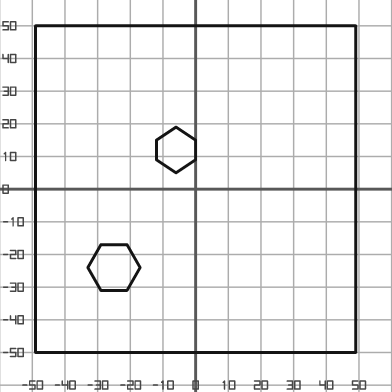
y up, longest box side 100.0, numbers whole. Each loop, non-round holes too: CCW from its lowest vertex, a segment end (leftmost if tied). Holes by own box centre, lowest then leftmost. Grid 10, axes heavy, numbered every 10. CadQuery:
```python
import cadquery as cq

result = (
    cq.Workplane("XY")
    .moveTo(-49.0, -50.0)
    .lineTo(49.0, -50.0)
    .lineTo(49.0, 50.0)
    .lineTo(-49.0, 50.0)
    .close()
    .moveTo(-29.0, -31.0)
    .lineTo(-21.0, -31.0)
    .lineTo(-17.0, -24.0)
    .lineTo(-21.0, -17.0)
    .lineTo(-29.0, -17.0)
    .lineTo(-33.0, -24.0)
    .close()
    .moveTo(-6.0, 5.0)
    .lineTo(0.0, 9.0)
    .lineTo(0.0, 15.0)
    .lineTo(-6.0, 19.0)
    .lineTo(-12.0, 15.0)
    .lineTo(-12.0, 9.0)
    .close()
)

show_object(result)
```